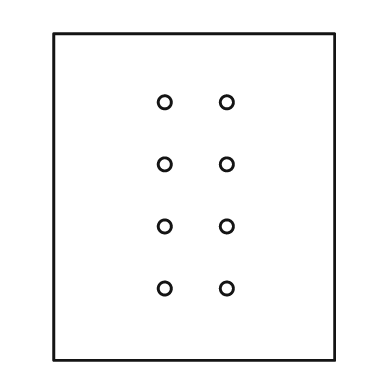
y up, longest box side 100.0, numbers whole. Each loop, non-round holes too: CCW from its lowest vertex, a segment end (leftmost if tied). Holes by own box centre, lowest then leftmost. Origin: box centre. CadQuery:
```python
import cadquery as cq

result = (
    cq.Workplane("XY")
    .moveTo(-43.0, -50.0)
    .lineTo(43.0, -50.0)
    .lineTo(43.0, 50.0)
    .lineTo(-43.0, 50.0)
    .close()
    .moveTo(-9.0, -28.0)
    .circle(2.0)
    .moveTo(10.0, -28.0)
    .circle(2.0)
    .moveTo(-9.0, -9.0)
    .circle(2.0)
    .moveTo(10.0, -9.0)
    .circle(2.0)
    .moveTo(-9.0, 10.0)
    .circle(2.0)
    .moveTo(10.0, 10.0)
    .circle(2.0)
    .moveTo(-9.0, 29.0)
    .circle(2.0)
    .moveTo(10.0, 29.0)
    .circle(2.0)
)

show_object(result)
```